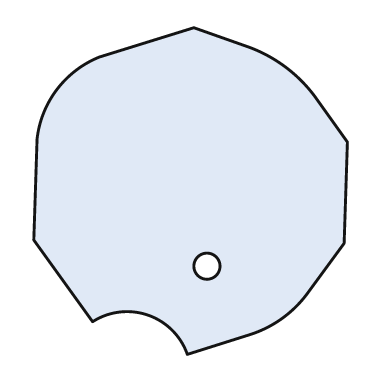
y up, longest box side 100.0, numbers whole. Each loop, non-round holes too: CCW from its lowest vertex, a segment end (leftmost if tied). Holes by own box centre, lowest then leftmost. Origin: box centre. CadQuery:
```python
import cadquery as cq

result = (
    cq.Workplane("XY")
    .moveTo(-1.0, -50.0)
    .lineTo(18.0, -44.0)
    .threePointArc((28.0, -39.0), (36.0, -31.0))
    .lineTo(47.0, -16.0)
    .lineTo(48.0, 15.0)
    .lineTo(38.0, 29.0)
    .threePointArc((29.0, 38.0), (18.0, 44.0))
    .lineTo(1.0, 50.0)
    .lineTo(-28.0, 41.0)
    .threePointArc((-41.0, 31.0), (-47.0, 16.0))
    .lineTo(-48.0, -15.0)
    .lineTo(-30.0, -40.0)
    .threePointArc((-13.0, -38.0), (-1.0, -50.0))
    .close()
    .moveTo(5.0, -23.0)
    .circle(4.0)
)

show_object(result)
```